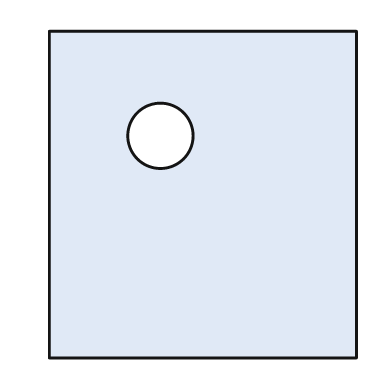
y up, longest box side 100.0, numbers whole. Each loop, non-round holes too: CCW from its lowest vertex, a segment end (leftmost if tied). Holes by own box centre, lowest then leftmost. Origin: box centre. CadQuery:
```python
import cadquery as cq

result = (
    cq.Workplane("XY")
    .moveTo(-47.0, -50.0)
    .lineTo(47.0, -50.0)
    .lineTo(47.0, 50.0)
    .lineTo(-47.0, 50.0)
    .close()
    .moveTo(-13.0, 18.0)
    .circle(10.0)
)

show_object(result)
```